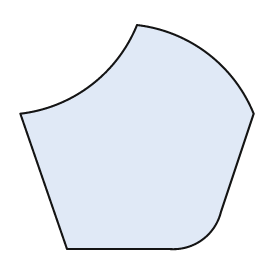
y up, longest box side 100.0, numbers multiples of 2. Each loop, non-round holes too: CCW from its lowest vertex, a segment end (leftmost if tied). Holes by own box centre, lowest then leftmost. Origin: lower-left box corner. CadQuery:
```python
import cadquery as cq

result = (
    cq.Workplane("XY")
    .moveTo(20.0, 0.0)
    .lineTo(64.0, 0.0)
    .threePointArc((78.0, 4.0), (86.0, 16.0))
    .lineTo(100.0, 58.0)
    .threePointArc((80.0, 84.0), (50.0, 96.0))
    .threePointArc((30.0, 70.0), (0.0, 58.0))
    .close()
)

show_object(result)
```